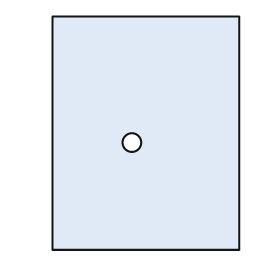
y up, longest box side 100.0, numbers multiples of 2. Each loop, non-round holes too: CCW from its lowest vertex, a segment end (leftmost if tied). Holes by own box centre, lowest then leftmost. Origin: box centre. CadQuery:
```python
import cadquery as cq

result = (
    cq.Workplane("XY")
    .moveTo(-40.0, -50.0)
    .lineTo(40.0, -50.0)
    .lineTo(40.0, 50.0)
    .lineTo(-40.0, 50.0)
    .close()
    .moveTo(-6.0, -4.0)
    .circle(4.0)
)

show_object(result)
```